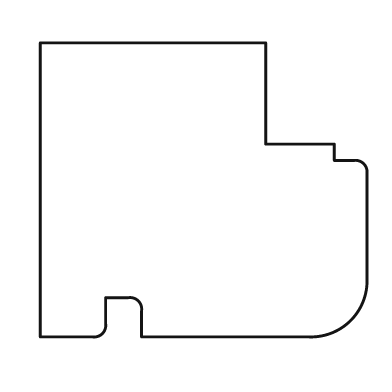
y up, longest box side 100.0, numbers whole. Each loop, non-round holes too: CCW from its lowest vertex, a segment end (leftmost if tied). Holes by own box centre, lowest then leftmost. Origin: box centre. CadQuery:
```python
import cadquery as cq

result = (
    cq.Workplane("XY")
    .moveTo(-50.0, -45.0)
    .lineTo(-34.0, -45.0)
    .threePointArc((-31.0, -44.0), (-30.0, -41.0))
    .lineTo(-30.0, -33.0)
    .lineTo(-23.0, -33.0)
    .threePointArc((-20.0, -34.0), (-19.0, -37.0))
    .lineTo(-19.0, -45.0)
    .lineTo(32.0, -45.0)
    .threePointArc((45.0, -40.0), (50.0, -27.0))
    .lineTo(50.0, 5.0)
    .threePointArc((49.0, 8.0), (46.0, 9.0))
    .lineTo(40.0, 9.0)
    .lineTo(40.0, 14.0)
    .lineTo(19.0, 14.0)
    .lineTo(19.0, 45.0)
    .lineTo(-50.0, 45.0)
    .close()
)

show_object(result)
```